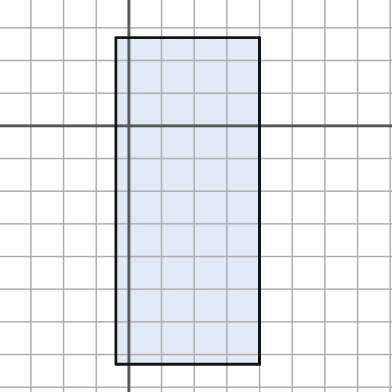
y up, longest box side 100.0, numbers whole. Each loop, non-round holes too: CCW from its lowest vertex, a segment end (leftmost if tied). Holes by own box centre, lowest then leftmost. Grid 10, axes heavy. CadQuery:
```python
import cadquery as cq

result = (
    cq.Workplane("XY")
    .moveTo(-4.0, -73.0)
    .lineTo(40.0, -73.0)
    .lineTo(40.0, 27.0)
    .lineTo(-4.0, 27.0)
    .close()
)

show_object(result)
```